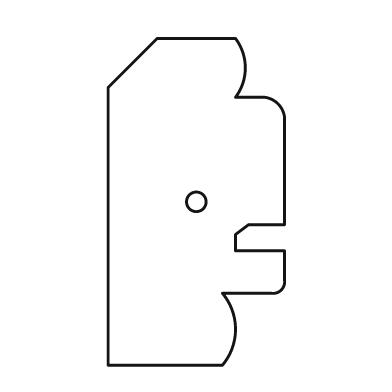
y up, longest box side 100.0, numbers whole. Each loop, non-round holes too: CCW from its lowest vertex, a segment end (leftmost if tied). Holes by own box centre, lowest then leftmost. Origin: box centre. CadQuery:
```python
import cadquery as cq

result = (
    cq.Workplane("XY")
    .moveTo(-27.0, -50.0)
    .lineTo(8.0, -50.0)
    .threePointArc((12.0, -39.0), (8.0, -28.0))
    .lineTo(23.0, -28.0)
    .threePointArc((26.0, -27.0), (27.0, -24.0))
    .lineTo(27.0, -15.0)
    .lineTo(12.0, -15.0)
    .lineTo(12.0, -10.0)
    .lineTo(16.0, -7.0)
    .lineTo(27.0, -7.0)
    .lineTo(27.0, 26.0)
    .threePointArc((25.0, 30.0), (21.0, 32.0))
    .lineTo(12.0, 32.0)
    .threePointArc((15.0, 41.0), (12.0, 50.0))
    .lineTo(-12.0, 50.0)
    .lineTo(-27.0, 35.0)
    .close()
    .moveTo(0.0, 0.0)
    .circle(3.0)
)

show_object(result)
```